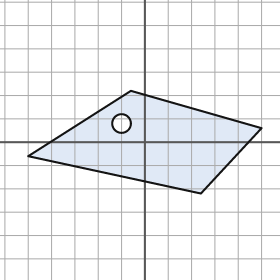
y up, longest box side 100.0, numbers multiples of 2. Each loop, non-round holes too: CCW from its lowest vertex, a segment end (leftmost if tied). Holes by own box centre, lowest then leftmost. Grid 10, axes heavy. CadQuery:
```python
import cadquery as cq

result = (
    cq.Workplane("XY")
    .moveTo(24.0, -22.0)
    .lineTo(50.0, 6.0)
    .lineTo(-6.0, 22.0)
    .lineTo(-50.0, -6.0)
    .close()
    .moveTo(-10.0, 8.0)
    .circle(4.0)
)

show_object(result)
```